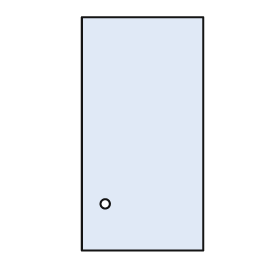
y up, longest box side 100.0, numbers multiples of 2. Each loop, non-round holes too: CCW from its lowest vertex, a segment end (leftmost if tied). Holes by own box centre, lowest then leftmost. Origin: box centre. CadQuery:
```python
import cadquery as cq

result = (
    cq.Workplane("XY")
    .moveTo(-26.0, -50.0)
    .lineTo(26.0, -50.0)
    .lineTo(26.0, 50.0)
    .lineTo(-26.0, 50.0)
    .close()
    .moveTo(-16.0, -30.0)
    .circle(2.0)
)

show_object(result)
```